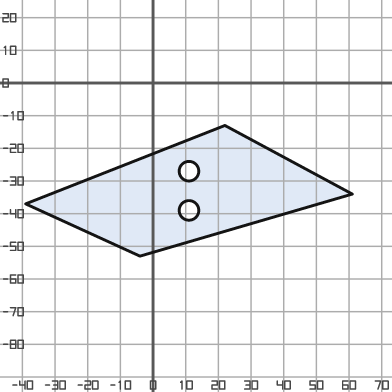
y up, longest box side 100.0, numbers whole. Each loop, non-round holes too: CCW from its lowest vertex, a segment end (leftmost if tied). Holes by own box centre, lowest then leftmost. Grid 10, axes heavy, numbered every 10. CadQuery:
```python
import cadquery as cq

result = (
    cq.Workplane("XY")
    .moveTo(-4.0, -53.0)
    .lineTo(61.0, -34.0)
    .lineTo(22.0, -13.0)
    .lineTo(-39.0, -37.0)
    .close()
    .moveTo(11.0, -39.0)
    .circle(3.0)
    .moveTo(11.0, -27.0)
    .circle(3.0)
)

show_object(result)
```